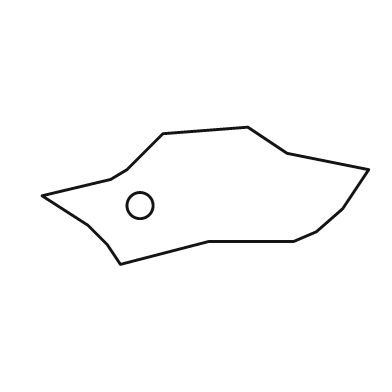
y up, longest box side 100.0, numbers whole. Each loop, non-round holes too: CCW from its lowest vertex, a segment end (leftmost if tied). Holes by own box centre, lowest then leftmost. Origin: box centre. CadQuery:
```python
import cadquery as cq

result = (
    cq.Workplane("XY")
    .moveTo(-26.0, -21.0)
    .lineTo(1.0, -14.0)
    .lineTo(27.0, -14.0)
    .lineTo(34.0, -11.0)
    .lineTo(42.0, -4.0)
    .lineTo(50.0, 8.0)
    .lineTo(25.0, 13.0)
    .lineTo(13.0, 21.0)
    .lineTo(-13.0, 19.0)
    .lineTo(-24.0, 8.0)
    .lineTo(-29.0, 5.0)
    .lineTo(-50.0, 0.0)
    .lineTo(-36.0, -9.0)
    .lineTo(-30.0, -15.0)
    .close()
    .moveTo(-20.0, -3.0)
    .circle(4.0)
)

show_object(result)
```